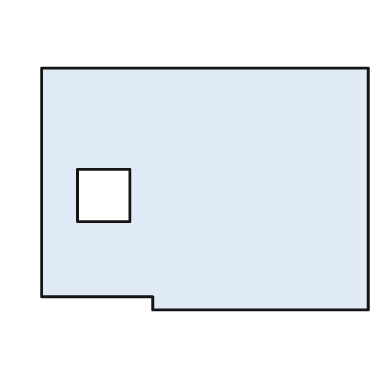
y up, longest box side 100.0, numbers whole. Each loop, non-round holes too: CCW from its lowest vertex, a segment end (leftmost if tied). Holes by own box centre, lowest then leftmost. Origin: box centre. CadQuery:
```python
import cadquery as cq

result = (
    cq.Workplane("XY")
    .moveTo(-16.0, -37.0)
    .lineTo(50.0, -37.0)
    .lineTo(50.0, 37.0)
    .lineTo(-50.0, 37.0)
    .lineTo(-50.0, -33.0)
    .lineTo(-16.0, -33.0)
    .close()
    .moveTo(-39.0, -10.0)
    .lineTo(-23.0, -10.0)
    .lineTo(-23.0, 6.0)
    .lineTo(-39.0, 6.0)
    .close()
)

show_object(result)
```